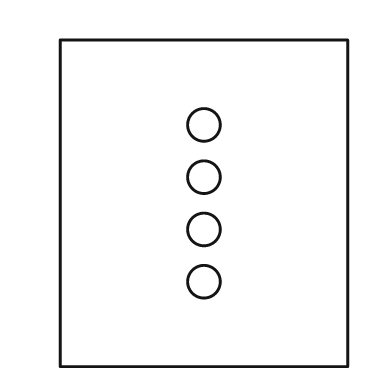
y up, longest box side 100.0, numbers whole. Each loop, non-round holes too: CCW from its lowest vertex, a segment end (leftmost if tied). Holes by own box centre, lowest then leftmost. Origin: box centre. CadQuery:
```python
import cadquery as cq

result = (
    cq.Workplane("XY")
    .moveTo(-44.0, -50.0)
    .lineTo(44.0, -50.0)
    .lineTo(44.0, 50.0)
    .lineTo(-44.0, 50.0)
    .close()
    .moveTo(0.0, -24.0)
    .circle(5.0)
    .moveTo(0.0, -8.0)
    .circle(5.0)
    .moveTo(0.0, 8.0)
    .circle(5.0)
    .moveTo(0.0, 24.0)
    .circle(5.0)
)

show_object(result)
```